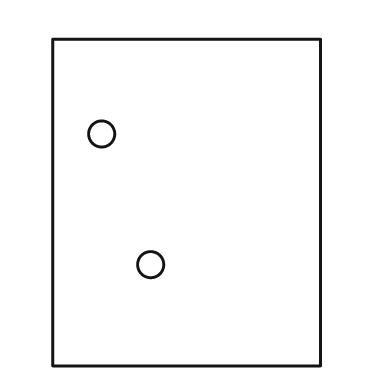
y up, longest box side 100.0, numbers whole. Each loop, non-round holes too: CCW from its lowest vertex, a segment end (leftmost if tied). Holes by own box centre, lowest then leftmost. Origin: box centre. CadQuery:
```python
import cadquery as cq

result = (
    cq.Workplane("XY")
    .moveTo(-41.0, -50.0)
    .lineTo(41.0, -50.0)
    .lineTo(41.0, 50.0)
    .lineTo(-41.0, 50.0)
    .close()
    .moveTo(-11.0, -19.0)
    .circle(4.0)
    .moveTo(-26.0, 21.0)
    .circle(4.0)
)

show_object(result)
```